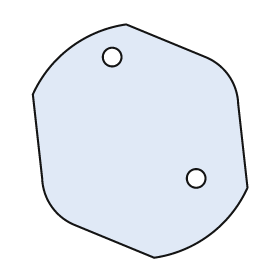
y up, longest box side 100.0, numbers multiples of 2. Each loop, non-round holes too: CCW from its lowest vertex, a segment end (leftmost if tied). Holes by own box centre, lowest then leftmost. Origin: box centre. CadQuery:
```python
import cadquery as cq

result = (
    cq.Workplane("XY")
    .moveTo(6.0, -50.0)
    .threePointArc((30.0, -40.0), (46.0, -20.0))
    .lineTo(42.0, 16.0)
    .threePointArc((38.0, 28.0), (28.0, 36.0))
    .lineTo(-6.0, 50.0)
    .threePointArc((-30.0, 40.0), (-46.0, 20.0))
    .lineTo(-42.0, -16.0)
    .threePointArc((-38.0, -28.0), (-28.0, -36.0))
    .close()
    .moveTo(24.0, -16.0)
    .circle(4.0)
    .moveTo(-12.0, 36.0)
    .circle(4.0)
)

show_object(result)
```